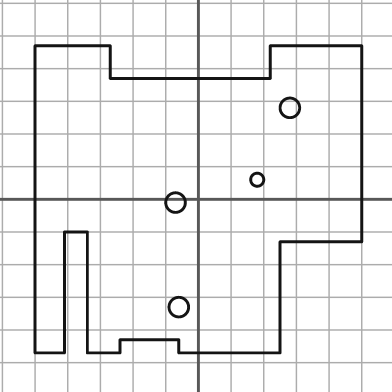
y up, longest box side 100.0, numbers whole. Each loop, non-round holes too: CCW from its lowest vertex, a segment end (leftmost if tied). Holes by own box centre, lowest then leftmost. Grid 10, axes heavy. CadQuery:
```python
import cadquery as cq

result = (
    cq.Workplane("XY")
    .moveTo(-50.0, -47.0)
    .lineTo(-41.0, -47.0)
    .lineTo(-41.0, -10.0)
    .lineTo(-34.0, -10.0)
    .lineTo(-34.0, -47.0)
    .lineTo(-24.0, -47.0)
    .lineTo(-24.0, -43.0)
    .lineTo(-6.0, -43.0)
    .lineTo(-6.0, -47.0)
    .lineTo(25.0, -47.0)
    .lineTo(25.0, -13.0)
    .lineTo(50.0, -13.0)
    .lineTo(50.0, 47.0)
    .lineTo(22.0, 47.0)
    .lineTo(22.0, 37.0)
    .lineTo(-27.0, 37.0)
    .lineTo(-27.0, 47.0)
    .lineTo(-50.0, 47.0)
    .close()
    .moveTo(-6.0, -33.0)
    .circle(3.0)
    .moveTo(-7.0, -1.0)
    .circle(3.0)
    .moveTo(18.0, 6.0)
    .circle(2.0)
    .moveTo(28.0, 28.0)
    .circle(3.0)
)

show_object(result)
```